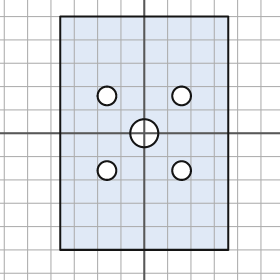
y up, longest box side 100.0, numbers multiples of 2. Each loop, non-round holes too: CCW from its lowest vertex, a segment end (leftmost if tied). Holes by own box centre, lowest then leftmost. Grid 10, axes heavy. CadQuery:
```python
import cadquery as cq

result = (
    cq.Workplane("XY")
    .moveTo(-36.0, -50.0)
    .lineTo(36.0, -50.0)
    .lineTo(36.0, 50.0)
    .lineTo(-36.0, 50.0)
    .close()
    .moveTo(-16.0, -16.0)
    .circle(4.0)
    .moveTo(16.0, -16.0)
    .circle(4.0)
    .moveTo(0.0, 0.0)
    .circle(6.0)
    .moveTo(-16.0, 16.0)
    .circle(4.0)
    .moveTo(16.0, 16.0)
    .circle(4.0)
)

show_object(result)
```